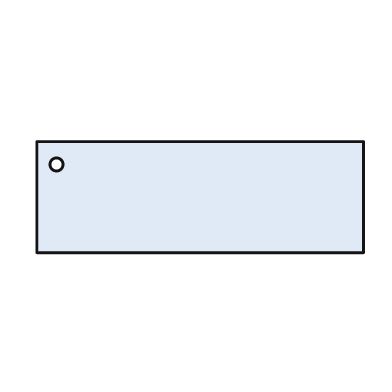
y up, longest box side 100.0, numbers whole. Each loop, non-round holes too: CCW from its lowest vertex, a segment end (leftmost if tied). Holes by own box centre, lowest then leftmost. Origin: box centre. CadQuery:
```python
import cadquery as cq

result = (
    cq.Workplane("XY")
    .moveTo(-50.0, -17.0)
    .lineTo(50.0, -17.0)
    .lineTo(50.0, 17.0)
    .lineTo(-50.0, 17.0)
    .close()
    .moveTo(-44.0, 10.0)
    .circle(2.0)
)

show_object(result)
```